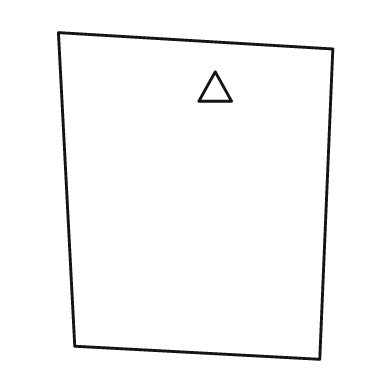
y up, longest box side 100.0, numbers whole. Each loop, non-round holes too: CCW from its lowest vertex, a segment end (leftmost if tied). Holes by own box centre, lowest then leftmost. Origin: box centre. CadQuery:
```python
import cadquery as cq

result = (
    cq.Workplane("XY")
    .moveTo(38.0, -50.0)
    .lineTo(42.0, 45.0)
    .lineTo(-42.0, 50.0)
    .lineTo(-37.0, -46.0)
    .close()
    .moveTo(1.0, 29.0)
    .lineTo(11.0, 29.0)
    .lineTo(6.0, 38.0)
    .close()
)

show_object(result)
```